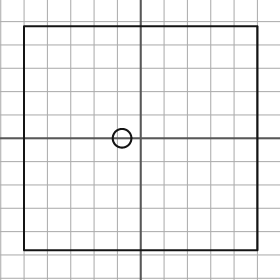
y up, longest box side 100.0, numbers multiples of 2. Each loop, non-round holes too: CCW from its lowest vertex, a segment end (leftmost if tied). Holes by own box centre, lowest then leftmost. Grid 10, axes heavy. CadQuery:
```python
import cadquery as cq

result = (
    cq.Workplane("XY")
    .moveTo(-50.0, -48.0)
    .lineTo(50.0, -48.0)
    .lineTo(50.0, 48.0)
    .lineTo(-50.0, 48.0)
    .close()
    .moveTo(-8.0, 0.0)
    .circle(4.0)
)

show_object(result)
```